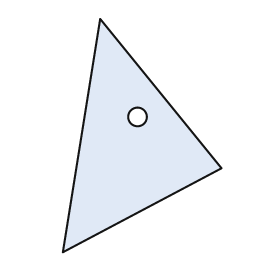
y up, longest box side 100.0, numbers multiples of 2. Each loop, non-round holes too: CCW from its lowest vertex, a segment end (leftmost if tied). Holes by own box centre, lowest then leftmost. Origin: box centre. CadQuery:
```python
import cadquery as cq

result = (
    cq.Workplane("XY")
    .moveTo(-34.0, -50.0)
    .lineTo(34.0, -14.0)
    .lineTo(-18.0, 50.0)
    .close()
    .moveTo(-2.0, 8.0)
    .circle(4.0)
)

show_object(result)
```